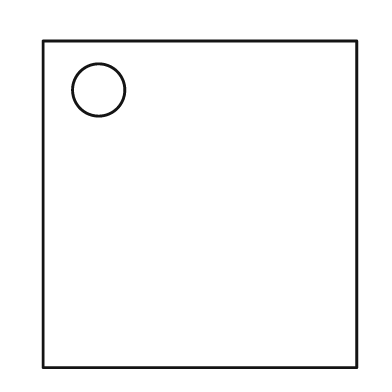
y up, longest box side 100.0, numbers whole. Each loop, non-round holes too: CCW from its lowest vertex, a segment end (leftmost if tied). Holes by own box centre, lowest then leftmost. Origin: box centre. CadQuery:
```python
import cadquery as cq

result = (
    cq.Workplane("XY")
    .moveTo(-48.0, -50.0)
    .lineTo(48.0, -50.0)
    .lineTo(48.0, 50.0)
    .lineTo(-48.0, 50.0)
    .close()
    .moveTo(-31.0, 35.0)
    .circle(8.0)
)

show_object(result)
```